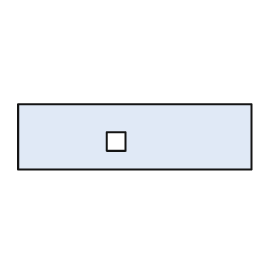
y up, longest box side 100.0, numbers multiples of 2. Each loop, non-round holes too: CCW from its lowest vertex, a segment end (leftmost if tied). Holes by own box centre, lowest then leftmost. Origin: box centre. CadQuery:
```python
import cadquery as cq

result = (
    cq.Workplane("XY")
    .moveTo(-50.0, -14.0)
    .lineTo(50.0, -14.0)
    .lineTo(50.0, 14.0)
    .lineTo(-50.0, 14.0)
    .close()
    .moveTo(-12.0, -6.0)
    .lineTo(-4.0, -6.0)
    .lineTo(-4.0, 2.0)
    .lineTo(-12.0, 2.0)
    .close()
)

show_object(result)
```